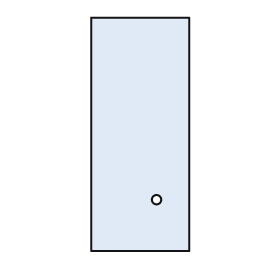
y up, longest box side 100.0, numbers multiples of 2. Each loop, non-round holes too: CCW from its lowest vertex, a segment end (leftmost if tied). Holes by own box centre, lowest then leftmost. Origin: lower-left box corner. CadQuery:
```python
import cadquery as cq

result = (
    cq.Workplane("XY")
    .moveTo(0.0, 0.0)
    .lineTo(42.0, 0.0)
    .lineTo(42.0, 100.0)
    .lineTo(0.0, 100.0)
    .close()
    .moveTo(28.0, 22.0)
    .circle(2.0)
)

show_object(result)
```